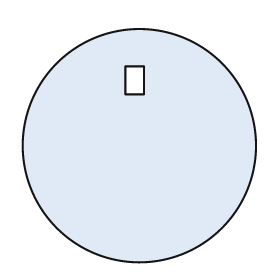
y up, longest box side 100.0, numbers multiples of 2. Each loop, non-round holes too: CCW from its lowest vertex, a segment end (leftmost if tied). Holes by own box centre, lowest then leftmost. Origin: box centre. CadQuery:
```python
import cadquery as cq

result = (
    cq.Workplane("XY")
    .moveTo(0.0, 0.0)
    .circle(50.0)
    .moveTo(-6.0, 22.0)
    .lineTo(2.0, 22.0)
    .lineTo(2.0, 34.0)
    .lineTo(-6.0, 34.0)
    .close()
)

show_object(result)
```